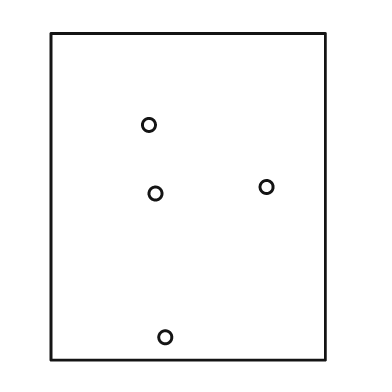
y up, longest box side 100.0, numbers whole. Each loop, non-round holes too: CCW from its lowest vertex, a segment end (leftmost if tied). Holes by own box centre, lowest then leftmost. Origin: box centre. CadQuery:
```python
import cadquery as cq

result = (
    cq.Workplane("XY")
    .moveTo(-42.0, -50.0)
    .lineTo(42.0, -50.0)
    .lineTo(42.0, 50.0)
    .lineTo(-42.0, 50.0)
    .close()
    .moveTo(-7.0, -43.0)
    .circle(2.0)
    .moveTo(-10.0, 1.0)
    .circle(2.0)
    .moveTo(24.0, 3.0)
    .circle(2.0)
    .moveTo(-12.0, 22.0)
    .circle(2.0)
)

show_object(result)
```